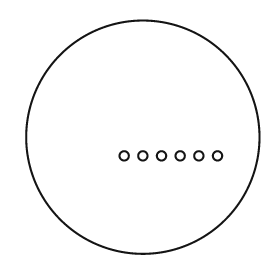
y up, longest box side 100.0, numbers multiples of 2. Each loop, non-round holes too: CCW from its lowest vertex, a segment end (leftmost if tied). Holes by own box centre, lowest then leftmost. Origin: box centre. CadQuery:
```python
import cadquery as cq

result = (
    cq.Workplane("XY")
    .moveTo(0.0, 0.0)
    .circle(50.0)
    .moveTo(-8.0, -8.0)
    .circle(2.0)
    .moveTo(0.0, -8.0)
    .circle(2.0)
    .moveTo(8.0, -8.0)
    .circle(2.0)
    .moveTo(16.0, -8.0)
    .circle(2.0)
    .moveTo(24.0, -8.0)
    .circle(2.0)
    .moveTo(32.0, -8.0)
    .circle(2.0)
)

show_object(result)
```